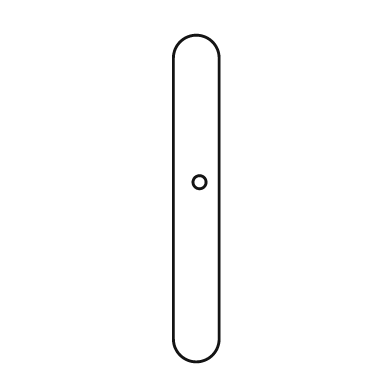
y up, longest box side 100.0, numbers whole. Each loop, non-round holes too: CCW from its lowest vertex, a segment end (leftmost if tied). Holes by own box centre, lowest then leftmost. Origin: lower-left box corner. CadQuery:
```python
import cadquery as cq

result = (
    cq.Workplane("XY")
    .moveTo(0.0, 7.0)
    .threePointArc((7.0, 0.0), (14.0, 7.0))
    .lineTo(14.0, 93.0)
    .threePointArc((7.0, 100.0), (0.0, 93.0))
    .close()
    .moveTo(8.0, 55.0)
    .circle(2.0)
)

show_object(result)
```